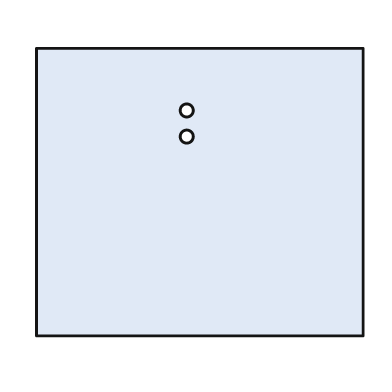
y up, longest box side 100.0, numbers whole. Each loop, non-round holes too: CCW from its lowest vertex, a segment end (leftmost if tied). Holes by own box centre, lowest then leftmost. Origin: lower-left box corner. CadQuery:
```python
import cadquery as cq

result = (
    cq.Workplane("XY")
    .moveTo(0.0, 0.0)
    .lineTo(100.0, 0.0)
    .lineTo(100.0, 88.0)
    .lineTo(0.0, 88.0)
    .close()
    .moveTo(46.0, 61.0)
    .circle(2.0)
    .moveTo(46.0, 69.0)
    .circle(2.0)
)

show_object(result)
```